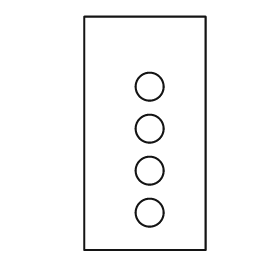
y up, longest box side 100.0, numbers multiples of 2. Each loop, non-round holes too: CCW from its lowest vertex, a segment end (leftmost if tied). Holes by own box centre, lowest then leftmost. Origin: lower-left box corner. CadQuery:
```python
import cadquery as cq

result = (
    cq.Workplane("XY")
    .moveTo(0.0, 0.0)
    .lineTo(52.0, 0.0)
    .lineTo(52.0, 100.0)
    .lineTo(0.0, 100.0)
    .close()
    .moveTo(28.0, 16.0)
    .circle(6.0)
    .moveTo(28.0, 34.0)
    .circle(6.0)
    .moveTo(28.0, 52.0)
    .circle(6.0)
    .moveTo(28.0, 70.0)
    .circle(6.0)
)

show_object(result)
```